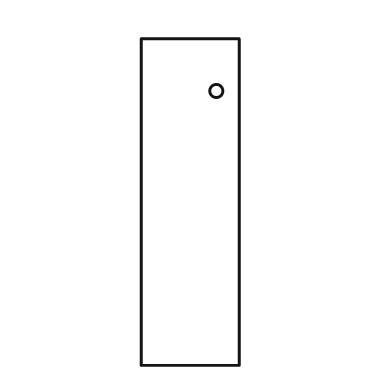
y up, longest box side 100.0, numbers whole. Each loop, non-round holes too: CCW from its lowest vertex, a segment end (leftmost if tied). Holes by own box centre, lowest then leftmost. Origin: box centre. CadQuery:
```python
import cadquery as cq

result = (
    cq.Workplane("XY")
    .moveTo(-15.0, -50.0)
    .lineTo(15.0, -50.0)
    .lineTo(15.0, 50.0)
    .lineTo(-15.0, 50.0)
    .close()
    .moveTo(8.0, 34.0)
    .circle(2.0)
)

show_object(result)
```